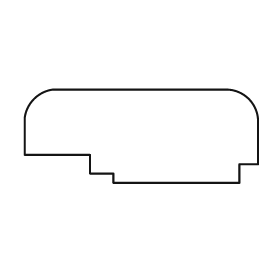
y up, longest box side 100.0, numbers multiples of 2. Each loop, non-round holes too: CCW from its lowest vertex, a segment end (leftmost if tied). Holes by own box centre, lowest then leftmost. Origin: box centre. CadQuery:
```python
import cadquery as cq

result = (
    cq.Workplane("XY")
    .moveTo(-12.0, -20.0)
    .lineTo(42.0, -20.0)
    .lineTo(42.0, -12.0)
    .lineTo(50.0, -12.0)
    .lineTo(50.0, 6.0)
    .threePointArc((46.0, 16.0), (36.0, 20.0))
    .lineTo(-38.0, 20.0)
    .threePointArc((-46.0, 16.0), (-50.0, 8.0))
    .lineTo(-50.0, -8.0)
    .lineTo(-22.0, -8.0)
    .lineTo(-22.0, -16.0)
    .lineTo(-12.0, -16.0)
    .close()
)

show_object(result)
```